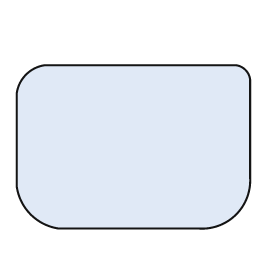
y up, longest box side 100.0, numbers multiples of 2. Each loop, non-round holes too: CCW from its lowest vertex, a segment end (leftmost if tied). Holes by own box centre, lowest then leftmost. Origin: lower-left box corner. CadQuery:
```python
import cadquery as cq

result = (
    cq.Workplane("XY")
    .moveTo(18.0, 0.0)
    .lineTo(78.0, 0.0)
    .threePointArc((94.0, 6.0), (100.0, 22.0))
    .lineTo(100.0, 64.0)
    .threePointArc((98.0, 68.0), (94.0, 70.0))
    .lineTo(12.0, 70.0)
    .threePointArc((4.0, 66.0), (0.0, 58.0))
    .lineTo(0.0, 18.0)
    .threePointArc((6.0, 6.0), (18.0, 0.0))
    .close()
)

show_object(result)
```